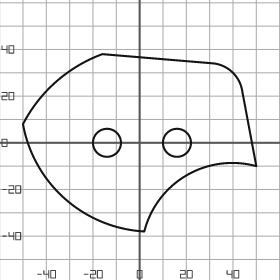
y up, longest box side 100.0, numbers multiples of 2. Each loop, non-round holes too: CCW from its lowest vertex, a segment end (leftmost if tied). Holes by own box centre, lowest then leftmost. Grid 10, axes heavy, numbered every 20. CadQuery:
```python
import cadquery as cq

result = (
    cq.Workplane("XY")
    .moveTo(2.0, -38.0)
    .threePointArc((20.0, -14.0), (50.0, -10.0))
    .lineTo(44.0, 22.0)
    .threePointArc((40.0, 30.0), (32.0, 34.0))
    .lineTo(-16.0, 38.0)
    .threePointArc((-36.0, 26.0), (-50.0, 8.0))
    .threePointArc((-32.0, -24.0), (2.0, -38.0))
    .close()
    .moveTo(-14.0, 0.0)
    .circle(6.0)
    .moveTo(16.0, 0.0)
    .circle(6.0)
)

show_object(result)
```